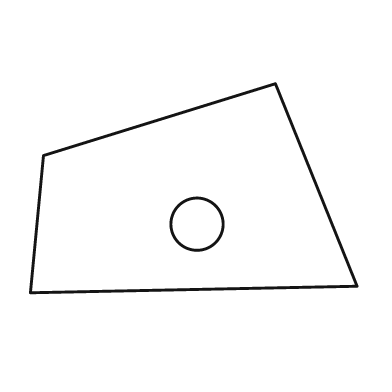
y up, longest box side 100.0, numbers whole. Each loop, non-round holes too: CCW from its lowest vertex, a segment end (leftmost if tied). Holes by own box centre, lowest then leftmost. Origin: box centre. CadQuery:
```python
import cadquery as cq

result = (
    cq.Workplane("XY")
    .moveTo(-50.0, -32.0)
    .lineTo(50.0, -30.0)
    .lineTo(25.0, 32.0)
    .lineTo(-46.0, 10.0)
    .close()
    .moveTo(1.0, -11.0)
    .circle(8.0)
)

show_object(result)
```